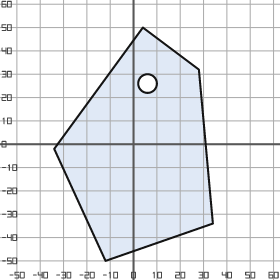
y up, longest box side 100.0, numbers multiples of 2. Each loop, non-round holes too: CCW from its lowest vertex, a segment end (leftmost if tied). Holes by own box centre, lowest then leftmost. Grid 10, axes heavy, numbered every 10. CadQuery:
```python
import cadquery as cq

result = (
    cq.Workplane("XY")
    .moveTo(-12.0, -50.0)
    .lineTo(34.0, -34.0)
    .lineTo(28.0, 32.0)
    .lineTo(4.0, 50.0)
    .lineTo(-34.0, -2.0)
    .close()
    .moveTo(6.0, 26.0)
    .circle(4.0)
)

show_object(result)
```